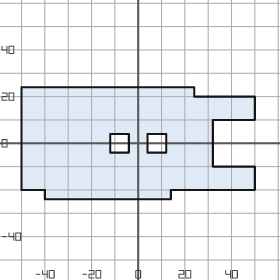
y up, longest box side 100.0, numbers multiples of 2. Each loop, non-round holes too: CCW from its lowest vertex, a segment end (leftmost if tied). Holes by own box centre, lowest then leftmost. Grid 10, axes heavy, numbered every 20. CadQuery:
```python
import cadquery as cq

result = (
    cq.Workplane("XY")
    .moveTo(-40.0, -24.0)
    .lineTo(14.0, -24.0)
    .lineTo(14.0, -20.0)
    .lineTo(50.0, -20.0)
    .lineTo(50.0, -10.0)
    .lineTo(32.0, -10.0)
    .lineTo(32.0, 10.0)
    .lineTo(50.0, 10.0)
    .lineTo(50.0, 20.0)
    .lineTo(24.0, 20.0)
    .lineTo(24.0, 24.0)
    .lineTo(-50.0, 24.0)
    .lineTo(-50.0, -20.0)
    .lineTo(-40.0, -20.0)
    .close()
    .moveTo(-12.0, -4.0)
    .lineTo(-4.0, -4.0)
    .lineTo(-4.0, 4.0)
    .lineTo(-12.0, 4.0)
    .close()
    .moveTo(4.0, -4.0)
    .lineTo(12.0, -4.0)
    .lineTo(12.0, 4.0)
    .lineTo(4.0, 4.0)
    .close()
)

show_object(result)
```